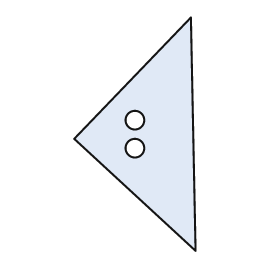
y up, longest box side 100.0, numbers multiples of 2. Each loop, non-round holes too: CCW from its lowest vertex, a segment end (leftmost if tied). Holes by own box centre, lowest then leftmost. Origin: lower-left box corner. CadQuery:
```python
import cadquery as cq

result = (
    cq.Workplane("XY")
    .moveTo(52.0, 0.0)
    .lineTo(50.0, 100.0)
    .lineTo(0.0, 48.0)
    .close()
    .moveTo(26.0, 44.0)
    .circle(4.0)
    .moveTo(26.0, 56.0)
    .circle(4.0)
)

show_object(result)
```